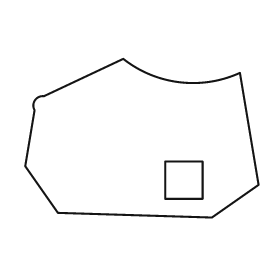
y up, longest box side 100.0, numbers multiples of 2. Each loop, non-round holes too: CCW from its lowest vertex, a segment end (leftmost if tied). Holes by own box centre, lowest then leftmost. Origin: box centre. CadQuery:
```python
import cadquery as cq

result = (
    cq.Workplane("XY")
    .moveTo(30.0, -34.0)
    .lineTo(50.0, -20.0)
    .lineTo(42.0, 28.0)
    .threePointArc((16.0, 24.0), (-8.0, 34.0))
    .lineTo(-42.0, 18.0)
    .threePointArc((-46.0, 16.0), (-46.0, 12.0))
    .lineTo(-50.0, -12.0)
    .lineTo(-36.0, -32.0)
    .close()
    .moveTo(10.0, -26.0)
    .lineTo(26.0, -26.0)
    .lineTo(26.0, -10.0)
    .lineTo(10.0, -10.0)
    .close()
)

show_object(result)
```